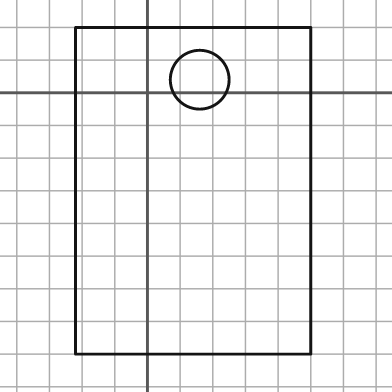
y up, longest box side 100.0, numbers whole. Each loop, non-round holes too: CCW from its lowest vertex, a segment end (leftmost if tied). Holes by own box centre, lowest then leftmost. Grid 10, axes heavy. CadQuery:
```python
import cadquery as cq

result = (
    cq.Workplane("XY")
    .moveTo(-22.0, -80.0)
    .lineTo(50.0, -80.0)
    .lineTo(50.0, 20.0)
    .lineTo(-22.0, 20.0)
    .close()
    .moveTo(16.0, 4.0)
    .circle(9.0)
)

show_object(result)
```